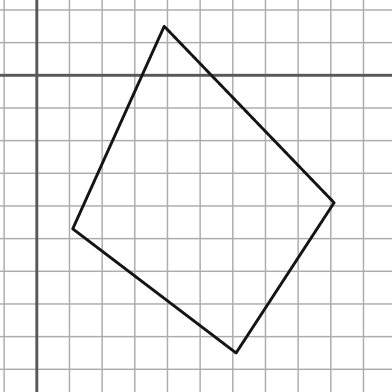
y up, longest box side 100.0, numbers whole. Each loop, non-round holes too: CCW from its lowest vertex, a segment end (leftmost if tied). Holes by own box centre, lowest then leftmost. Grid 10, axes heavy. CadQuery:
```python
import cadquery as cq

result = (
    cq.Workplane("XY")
    .moveTo(61.0, -85.0)
    .lineTo(91.0, -39.0)
    .lineTo(39.0, 15.0)
    .lineTo(11.0, -47.0)
    .close()
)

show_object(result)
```